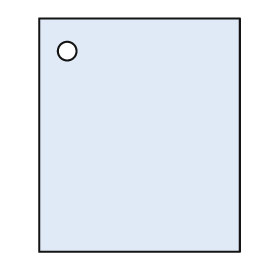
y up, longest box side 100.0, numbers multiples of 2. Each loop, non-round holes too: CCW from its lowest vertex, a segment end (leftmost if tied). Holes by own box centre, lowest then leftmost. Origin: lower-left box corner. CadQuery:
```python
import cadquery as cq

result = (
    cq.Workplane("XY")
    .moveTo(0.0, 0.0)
    .lineTo(86.0, 0.0)
    .lineTo(86.0, 100.0)
    .lineTo(0.0, 100.0)
    .close()
    .moveTo(12.0, 86.0)
    .circle(4.0)
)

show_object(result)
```